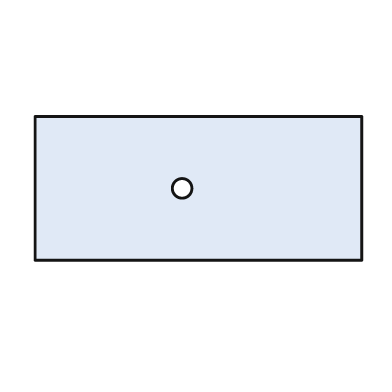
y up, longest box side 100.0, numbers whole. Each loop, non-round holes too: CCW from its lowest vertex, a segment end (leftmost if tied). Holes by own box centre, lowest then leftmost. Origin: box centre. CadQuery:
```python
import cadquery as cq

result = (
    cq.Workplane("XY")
    .moveTo(-50.0, -22.0)
    .lineTo(50.0, -22.0)
    .lineTo(50.0, 22.0)
    .lineTo(-50.0, 22.0)
    .close()
    .moveTo(-5.0, 0.0)
    .circle(3.0)
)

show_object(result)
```